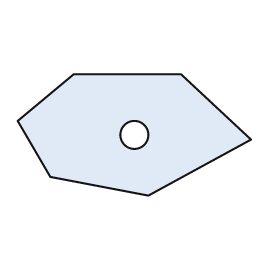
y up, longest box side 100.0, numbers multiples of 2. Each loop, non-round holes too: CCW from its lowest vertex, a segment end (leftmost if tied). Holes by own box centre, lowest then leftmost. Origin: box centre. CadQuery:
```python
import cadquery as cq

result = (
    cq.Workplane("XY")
    .moveTo(6.0, -26.0)
    .lineTo(50.0, -2.0)
    .lineTo(20.0, 26.0)
    .lineTo(-26.0, 26.0)
    .lineTo(-50.0, 6.0)
    .lineTo(-36.0, -18.0)
    .close()
    .moveTo(0.0, 0.0)
    .circle(6.0)
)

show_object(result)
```